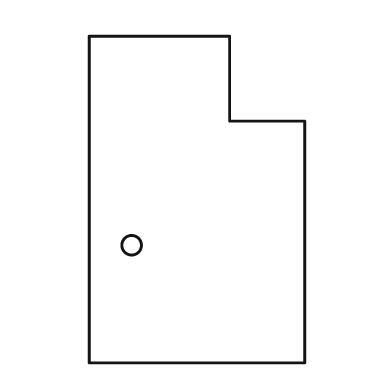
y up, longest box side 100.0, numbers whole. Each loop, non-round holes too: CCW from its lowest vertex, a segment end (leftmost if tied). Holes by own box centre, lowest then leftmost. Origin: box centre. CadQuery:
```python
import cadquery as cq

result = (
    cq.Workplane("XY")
    .moveTo(-33.0, -50.0)
    .lineTo(33.0, -50.0)
    .lineTo(33.0, 24.0)
    .lineTo(10.0, 24.0)
    .lineTo(10.0, 50.0)
    .lineTo(-33.0, 50.0)
    .close()
    .moveTo(-20.0, -14.0)
    .circle(3.0)
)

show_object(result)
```